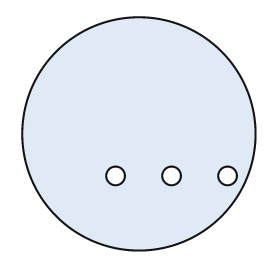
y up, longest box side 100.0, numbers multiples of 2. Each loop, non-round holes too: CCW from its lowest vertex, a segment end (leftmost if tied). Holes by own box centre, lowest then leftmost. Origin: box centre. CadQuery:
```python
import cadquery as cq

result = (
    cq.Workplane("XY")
    .moveTo(0.0, 0.0)
    .circle(50.0)
    .moveTo(-10.0, -18.0)
    .circle(4.0)
    .moveTo(14.0, -18.0)
    .circle(4.0)
    .moveTo(38.0, -18.0)
    .circle(4.0)
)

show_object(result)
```